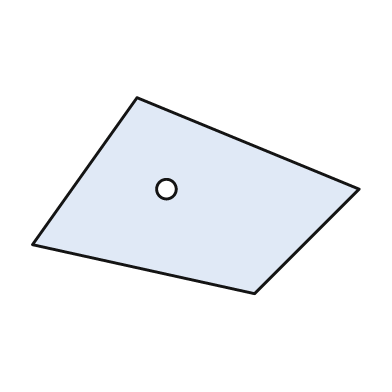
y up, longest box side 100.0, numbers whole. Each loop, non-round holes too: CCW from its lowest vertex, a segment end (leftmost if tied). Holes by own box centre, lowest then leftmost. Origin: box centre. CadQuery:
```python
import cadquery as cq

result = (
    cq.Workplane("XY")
    .moveTo(18.0, -30.0)
    .lineTo(50.0, 2.0)
    .lineTo(-18.0, 30.0)
    .lineTo(-50.0, -15.0)
    .close()
    .moveTo(-9.0, 2.0)
    .circle(3.0)
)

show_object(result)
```